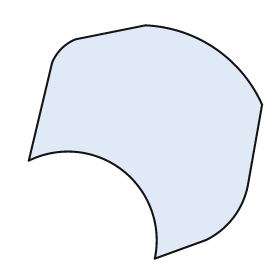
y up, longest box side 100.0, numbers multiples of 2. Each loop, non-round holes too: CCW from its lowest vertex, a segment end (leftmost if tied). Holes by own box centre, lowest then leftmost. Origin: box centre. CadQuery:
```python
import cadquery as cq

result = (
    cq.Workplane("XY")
    .moveTo(4.0, -50.0)
    .lineTo(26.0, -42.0)
    .threePointArc((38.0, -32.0), (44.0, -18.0))
    .lineTo(50.0, 16.0)
    .threePointArc((30.0, 40.0), (0.0, 50.0))
    .lineTo(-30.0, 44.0)
    .threePointArc((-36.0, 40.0), (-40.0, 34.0))
    .lineTo(-50.0, -8.0)
    .threePointArc((-10.0, -12.0), (4.0, -50.0))
    .close()
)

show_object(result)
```